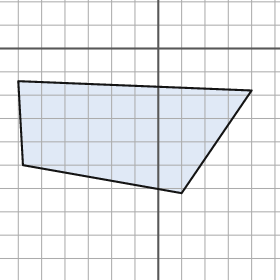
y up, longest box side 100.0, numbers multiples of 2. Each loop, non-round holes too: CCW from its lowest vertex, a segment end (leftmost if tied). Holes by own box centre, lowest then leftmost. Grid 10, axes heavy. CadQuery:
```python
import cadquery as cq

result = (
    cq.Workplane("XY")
    .moveTo(10.0, -62.0)
    .lineTo(40.0, -18.0)
    .lineTo(-60.0, -14.0)
    .lineTo(-58.0, -50.0)
    .close()
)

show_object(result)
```